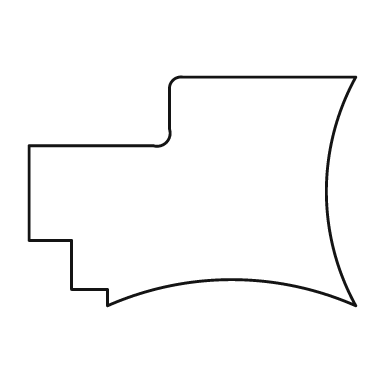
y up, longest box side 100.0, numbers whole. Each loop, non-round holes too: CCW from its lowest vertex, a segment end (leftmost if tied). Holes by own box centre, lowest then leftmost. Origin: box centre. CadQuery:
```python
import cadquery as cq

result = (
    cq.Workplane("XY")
    .moveTo(-26.0, -35.0)
    .threePointArc((12.0, -27.0), (50.0, -35.0))
    .threePointArc((41.0, 0.0), (50.0, 35.0))
    .lineTo(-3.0, 35.0)
    .threePointArc((-6.0, 34.0), (-7.0, 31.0))
    .lineTo(-7.0, 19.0)
    .threePointArc((-8.0, 15.0), (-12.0, 14.0))
    .lineTo(-50.0, 14.0)
    .lineTo(-50.0, -15.0)
    .lineTo(-37.0, -15.0)
    .lineTo(-37.0, -30.0)
    .lineTo(-26.0, -30.0)
    .close()
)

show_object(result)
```